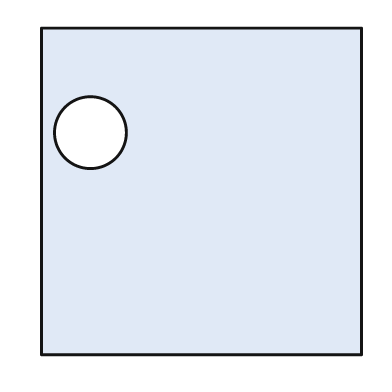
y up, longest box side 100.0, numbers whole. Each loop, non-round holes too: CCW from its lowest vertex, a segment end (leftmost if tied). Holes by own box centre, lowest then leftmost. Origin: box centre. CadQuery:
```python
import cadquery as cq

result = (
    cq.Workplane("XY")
    .moveTo(-49.0, -50.0)
    .lineTo(49.0, -50.0)
    .lineTo(49.0, 50.0)
    .lineTo(-49.0, 50.0)
    .close()
    .moveTo(-34.0, 18.0)
    .circle(11.0)
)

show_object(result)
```